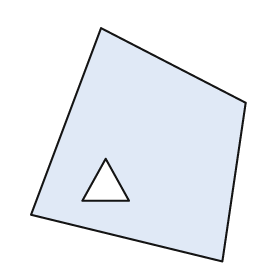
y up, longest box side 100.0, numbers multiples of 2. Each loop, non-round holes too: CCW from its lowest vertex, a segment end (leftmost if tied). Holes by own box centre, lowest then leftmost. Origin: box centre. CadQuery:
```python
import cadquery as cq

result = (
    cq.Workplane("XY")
    .moveTo(36.0, -50.0)
    .lineTo(46.0, 18.0)
    .lineTo(-16.0, 50.0)
    .lineTo(-46.0, -30.0)
    .close()
    .moveTo(-24.0, -24.0)
    .lineTo(-4.0, -24.0)
    .lineTo(-14.0, -6.0)
    .close()
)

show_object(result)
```